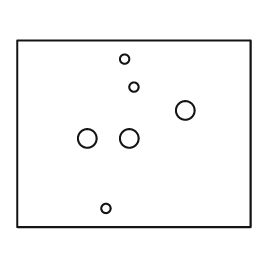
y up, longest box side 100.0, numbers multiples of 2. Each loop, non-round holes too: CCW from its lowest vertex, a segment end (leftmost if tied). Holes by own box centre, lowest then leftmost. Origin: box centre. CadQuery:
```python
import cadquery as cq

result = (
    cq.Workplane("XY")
    .moveTo(-50.0, -40.0)
    .lineTo(50.0, -40.0)
    .lineTo(50.0, 40.0)
    .lineTo(-50.0, 40.0)
    .close()
    .moveTo(-12.0, -32.0)
    .circle(2.0)
    .moveTo(-20.0, -2.0)
    .circle(4.0)
    .moveTo(-2.0, -2.0)
    .circle(4.0)
    .moveTo(22.0, 10.0)
    .circle(4.0)
    .moveTo(0.0, 20.0)
    .circle(2.0)
    .moveTo(-4.0, 32.0)
    .circle(2.0)
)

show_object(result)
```